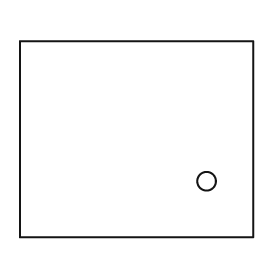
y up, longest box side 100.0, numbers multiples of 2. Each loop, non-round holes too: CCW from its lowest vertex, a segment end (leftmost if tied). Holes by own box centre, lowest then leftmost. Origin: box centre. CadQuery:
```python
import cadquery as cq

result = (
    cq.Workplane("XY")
    .moveTo(-50.0, -42.0)
    .lineTo(50.0, -42.0)
    .lineTo(50.0, 42.0)
    .lineTo(-50.0, 42.0)
    .close()
    .moveTo(30.0, -18.0)
    .circle(4.0)
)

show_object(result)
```